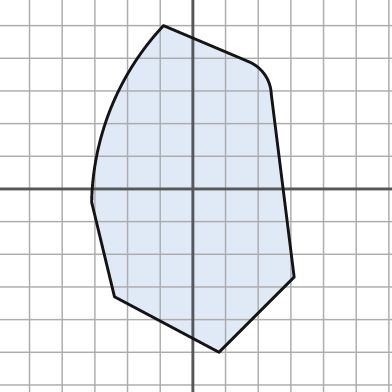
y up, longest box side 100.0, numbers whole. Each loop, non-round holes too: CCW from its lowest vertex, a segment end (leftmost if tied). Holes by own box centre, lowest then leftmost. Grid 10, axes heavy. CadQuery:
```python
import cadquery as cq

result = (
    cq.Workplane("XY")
    .moveTo(8.0, -50.0)
    .lineTo(31.0, -27.0)
    .lineTo(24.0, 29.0)
    .threePointArc((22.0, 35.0), (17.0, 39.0))
    .lineTo(-9.0, 50.0)
    .threePointArc((-25.0, 25.0), (-31.0, -4.0))
    .lineTo(-24.0, -33.0)
    .close()
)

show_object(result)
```